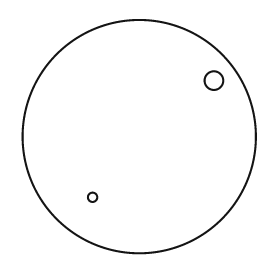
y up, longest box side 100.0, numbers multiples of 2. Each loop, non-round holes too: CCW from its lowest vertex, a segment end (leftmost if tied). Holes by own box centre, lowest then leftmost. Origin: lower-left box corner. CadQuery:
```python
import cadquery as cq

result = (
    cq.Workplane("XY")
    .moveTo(50.0, 50.0)
    .circle(50.0)
    .moveTo(30.0, 24.0)
    .circle(2.0)
    .moveTo(82.0, 74.0)
    .circle(4.0)
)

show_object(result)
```